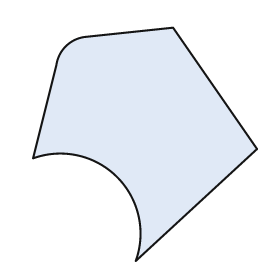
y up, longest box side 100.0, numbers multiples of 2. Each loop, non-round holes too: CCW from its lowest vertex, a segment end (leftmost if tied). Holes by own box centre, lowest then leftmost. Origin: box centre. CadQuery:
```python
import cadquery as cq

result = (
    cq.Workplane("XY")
    .moveTo(-4.0, -50.0)
    .lineTo(48.0, -2.0)
    .lineTo(12.0, 50.0)
    .lineTo(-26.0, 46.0)
    .threePointArc((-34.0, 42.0), (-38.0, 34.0))
    .lineTo(-48.0, -6.0)
    .threePointArc((-12.0, -14.0), (-4.0, -50.0))
    .close()
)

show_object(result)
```